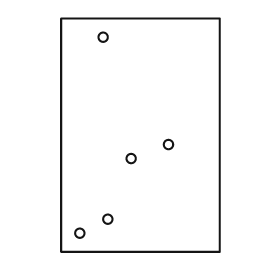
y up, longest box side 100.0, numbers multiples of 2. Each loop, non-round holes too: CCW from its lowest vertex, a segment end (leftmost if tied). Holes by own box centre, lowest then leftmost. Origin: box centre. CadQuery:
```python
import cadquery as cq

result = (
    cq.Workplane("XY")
    .moveTo(-34.0, -50.0)
    .lineTo(34.0, -50.0)
    .lineTo(34.0, 50.0)
    .lineTo(-34.0, 50.0)
    .close()
    .moveTo(-26.0, -42.0)
    .circle(2.0)
    .moveTo(-14.0, -36.0)
    .circle(2.0)
    .moveTo(-4.0, -10.0)
    .circle(2.0)
    .moveTo(12.0, -4.0)
    .circle(2.0)
    .moveTo(-16.0, 42.0)
    .circle(2.0)
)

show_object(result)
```